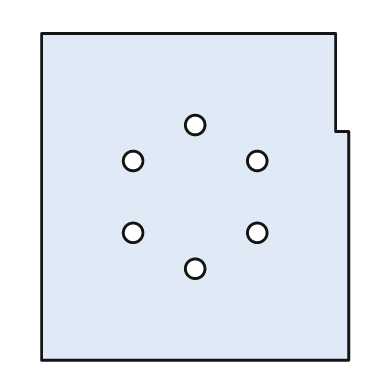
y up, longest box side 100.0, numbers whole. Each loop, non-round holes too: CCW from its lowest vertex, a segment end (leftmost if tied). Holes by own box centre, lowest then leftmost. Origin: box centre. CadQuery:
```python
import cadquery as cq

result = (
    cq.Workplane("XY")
    .moveTo(-47.0, -50.0)
    .lineTo(47.0, -50.0)
    .lineTo(47.0, 20.0)
    .lineTo(43.0, 20.0)
    .lineTo(43.0, 50.0)
    .lineTo(-47.0, 50.0)
    .close()
    .moveTo(0.0, -22.0)
    .circle(3.0)
    .moveTo(-19.0, -11.0)
    .circle(3.0)
    .moveTo(19.0, -11.0)
    .circle(3.0)
    .moveTo(-19.0, 11.0)
    .circle(3.0)
    .moveTo(19.0, 11.0)
    .circle(3.0)
    .moveTo(0.0, 22.0)
    .circle(3.0)
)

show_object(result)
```